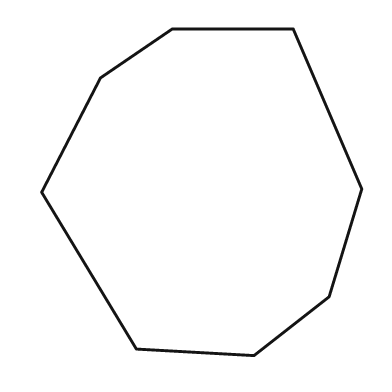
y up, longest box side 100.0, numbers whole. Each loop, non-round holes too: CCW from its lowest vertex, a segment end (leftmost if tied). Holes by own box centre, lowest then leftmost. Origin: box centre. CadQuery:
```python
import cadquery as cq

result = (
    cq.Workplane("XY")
    .moveTo(16.0, -50.0)
    .lineTo(39.0, -32.0)
    .lineTo(49.0, 1.0)
    .lineTo(28.0, 50.0)
    .lineTo(-9.0, 50.0)
    .lineTo(-31.0, 35.0)
    .lineTo(-49.0, 0.0)
    .lineTo(-20.0, -48.0)
    .close()
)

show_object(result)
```